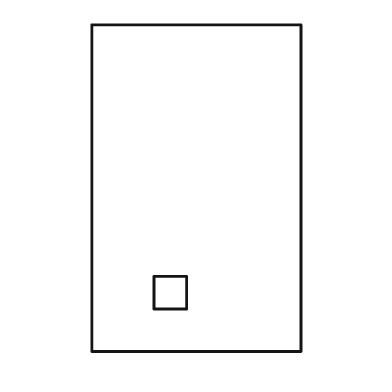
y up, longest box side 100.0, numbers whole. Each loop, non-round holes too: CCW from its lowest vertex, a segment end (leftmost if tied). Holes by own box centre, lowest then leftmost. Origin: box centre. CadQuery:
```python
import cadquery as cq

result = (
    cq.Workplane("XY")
    .moveTo(-32.0, -50.0)
    .lineTo(32.0, -50.0)
    .lineTo(32.0, 50.0)
    .lineTo(-32.0, 50.0)
    .close()
    .moveTo(-13.0, -37.0)
    .lineTo(-3.0, -37.0)
    .lineTo(-3.0, -27.0)
    .lineTo(-13.0, -27.0)
    .close()
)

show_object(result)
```